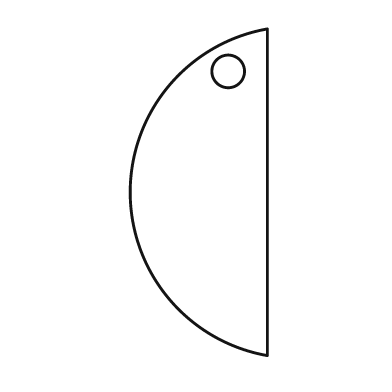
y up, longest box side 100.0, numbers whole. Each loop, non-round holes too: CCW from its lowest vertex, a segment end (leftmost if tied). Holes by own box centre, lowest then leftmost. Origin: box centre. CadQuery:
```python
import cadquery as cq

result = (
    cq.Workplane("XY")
    .moveTo(21.0, -50.0)
    .lineTo(21.0, 50.0)
    .threePointArc((-21.0, 0.0), (21.0, -50.0))
    .close()
    .moveTo(9.0, 37.0)
    .circle(5.0)
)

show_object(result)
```